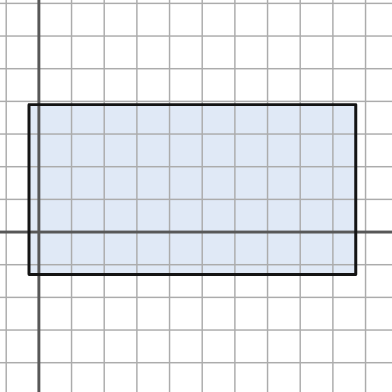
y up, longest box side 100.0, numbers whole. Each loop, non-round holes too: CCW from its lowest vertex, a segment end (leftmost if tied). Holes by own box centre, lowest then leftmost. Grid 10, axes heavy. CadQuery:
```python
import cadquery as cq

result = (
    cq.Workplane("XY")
    .moveTo(-3.0, -13.0)
    .lineTo(97.0, -13.0)
    .lineTo(97.0, 39.0)
    .lineTo(-3.0, 39.0)
    .close()
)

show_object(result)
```